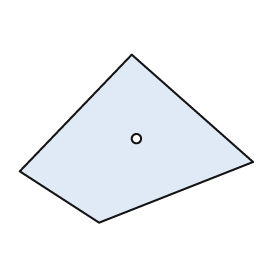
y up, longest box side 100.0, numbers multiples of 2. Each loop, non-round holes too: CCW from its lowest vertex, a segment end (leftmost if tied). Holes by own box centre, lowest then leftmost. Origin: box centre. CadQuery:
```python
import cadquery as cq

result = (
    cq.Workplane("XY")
    .moveTo(-16.0, -36.0)
    .lineTo(50.0, -10.0)
    .lineTo(-2.0, 36.0)
    .lineTo(-50.0, -14.0)
    .close()
    .moveTo(0.0, 0.0)
    .circle(2.0)
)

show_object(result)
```